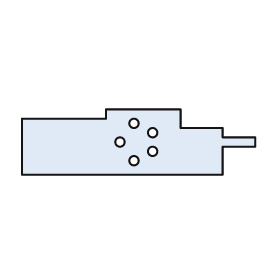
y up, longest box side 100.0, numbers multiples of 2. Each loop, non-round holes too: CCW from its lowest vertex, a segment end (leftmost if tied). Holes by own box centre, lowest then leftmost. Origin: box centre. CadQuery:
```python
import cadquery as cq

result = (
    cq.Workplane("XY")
    .moveTo(-50.0, -14.0)
    .lineTo(36.0, -14.0)
    .lineTo(36.0, -2.0)
    .lineTo(50.0, -2.0)
    .lineTo(50.0, 2.0)
    .lineTo(36.0, 2.0)
    .lineTo(36.0, 6.0)
    .lineTo(18.0, 6.0)
    .lineTo(18.0, 14.0)
    .lineTo(-14.0, 14.0)
    .lineTo(-14.0, 10.0)
    .lineTo(-50.0, 10.0)
    .close()
    .moveTo(-2.0, -8.0)
    .circle(2.0)
    .moveTo(6.0, -4.0)
    .circle(2.0)
    .moveTo(-8.0, 0.0)
    .circle(2.0)
    .moveTo(6.0, 4.0)
    .circle(2.0)
    .moveTo(-2.0, 8.0)
    .circle(2.0)
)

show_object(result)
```